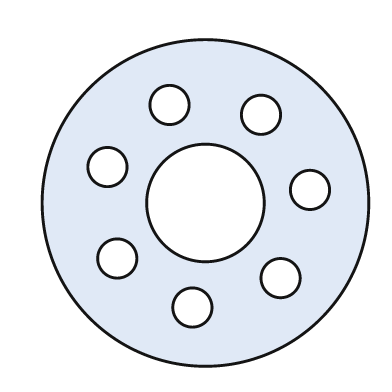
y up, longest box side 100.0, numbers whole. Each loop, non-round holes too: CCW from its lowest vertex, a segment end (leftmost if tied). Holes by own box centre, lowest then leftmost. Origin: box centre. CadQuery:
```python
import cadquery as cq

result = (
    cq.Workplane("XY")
    .moveTo(0.0, 0.0)
    .circle(50.0)
    .moveTo(-4.0, -32.0)
    .circle(6.0)
    .moveTo(23.0, -23.0)
    .circle(6.0)
    .moveTo(-27.0, -17.0)
    .circle(6.0)
    .moveTo(0.0, 0.0)
    .circle(18.0)
    .moveTo(32.0, 4.0)
    .circle(6.0)
    .moveTo(-30.0, 11.0)
    .circle(6.0)
    .moveTo(17.0, 27.0)
    .circle(6.0)
    .moveTo(-11.0, 30.0)
    .circle(6.0)
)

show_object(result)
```